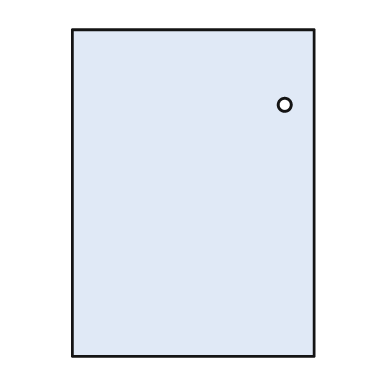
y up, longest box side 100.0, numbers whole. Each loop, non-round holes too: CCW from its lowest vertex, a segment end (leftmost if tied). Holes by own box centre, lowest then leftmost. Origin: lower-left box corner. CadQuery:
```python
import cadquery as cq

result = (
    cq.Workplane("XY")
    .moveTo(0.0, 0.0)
    .lineTo(74.0, 0.0)
    .lineTo(74.0, 100.0)
    .lineTo(0.0, 100.0)
    .close()
    .moveTo(65.0, 77.0)
    .circle(2.0)
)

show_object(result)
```